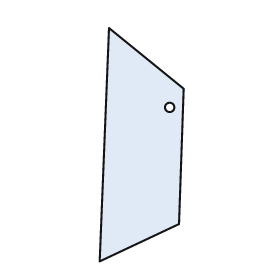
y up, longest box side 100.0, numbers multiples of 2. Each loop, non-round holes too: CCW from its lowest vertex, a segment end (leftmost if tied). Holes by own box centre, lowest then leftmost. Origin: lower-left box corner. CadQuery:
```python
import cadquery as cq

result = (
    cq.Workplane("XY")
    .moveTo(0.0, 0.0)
    .lineTo(34.0, 16.0)
    .lineTo(36.0, 74.0)
    .lineTo(4.0, 100.0)
    .close()
    .moveTo(30.0, 66.0)
    .circle(2.0)
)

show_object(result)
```